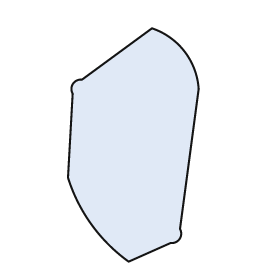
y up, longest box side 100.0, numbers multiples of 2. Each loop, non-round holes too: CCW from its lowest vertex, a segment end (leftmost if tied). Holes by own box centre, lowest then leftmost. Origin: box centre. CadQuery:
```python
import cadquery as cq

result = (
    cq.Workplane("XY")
    .moveTo(-2.0, -50.0)
    .lineTo(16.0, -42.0)
    .threePointArc((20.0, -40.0), (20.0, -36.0))
    .lineTo(28.0, 24.0)
    .threePointArc((22.0, 40.0), (8.0, 50.0))
    .lineTo(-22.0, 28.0)
    .threePointArc((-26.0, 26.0), (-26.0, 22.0))
    .lineTo(-28.0, -14.0)
    .threePointArc((-18.0, -34.0), (-2.0, -50.0))
    .close()
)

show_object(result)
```